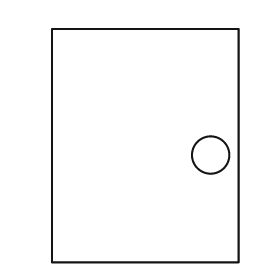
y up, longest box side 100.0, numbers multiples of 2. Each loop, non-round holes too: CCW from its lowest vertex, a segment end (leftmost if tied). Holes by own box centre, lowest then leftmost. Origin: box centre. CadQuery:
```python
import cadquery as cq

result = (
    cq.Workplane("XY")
    .moveTo(-40.0, -50.0)
    .lineTo(40.0, -50.0)
    .lineTo(40.0, 50.0)
    .lineTo(-40.0, 50.0)
    .close()
    .moveTo(28.0, -4.0)
    .circle(8.0)
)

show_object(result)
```